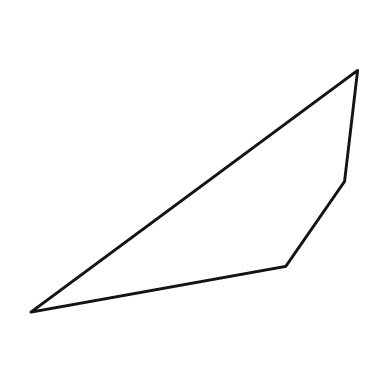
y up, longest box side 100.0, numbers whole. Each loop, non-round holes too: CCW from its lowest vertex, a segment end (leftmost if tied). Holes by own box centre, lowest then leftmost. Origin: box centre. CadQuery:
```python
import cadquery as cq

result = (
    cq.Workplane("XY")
    .moveTo(-50.0, -37.0)
    .lineTo(28.0, -23.0)
    .lineTo(46.0, 3.0)
    .lineTo(50.0, 37.0)
    .close()
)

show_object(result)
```